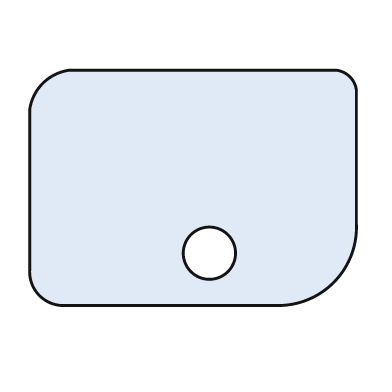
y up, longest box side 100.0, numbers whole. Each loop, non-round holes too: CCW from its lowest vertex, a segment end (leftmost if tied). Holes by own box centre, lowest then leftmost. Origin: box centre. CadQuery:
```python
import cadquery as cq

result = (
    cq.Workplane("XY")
    .moveTo(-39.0, -36.0)
    .lineTo(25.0, -36.0)
    .threePointArc((43.0, -29.0), (50.0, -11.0))
    .lineTo(50.0, 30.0)
    .threePointArc((48.0, 34.0), (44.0, 36.0))
    .lineTo(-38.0, 36.0)
    .threePointArc((-46.0, 32.0), (-50.0, 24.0))
    .lineTo(-50.0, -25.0)
    .threePointArc((-47.0, -33.0), (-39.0, -36.0))
    .close()
    .moveTo(5.0, -20.0)
    .circle(8.0)
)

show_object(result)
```